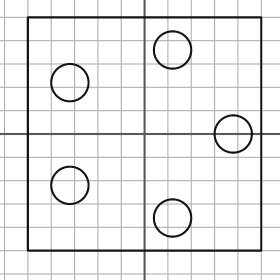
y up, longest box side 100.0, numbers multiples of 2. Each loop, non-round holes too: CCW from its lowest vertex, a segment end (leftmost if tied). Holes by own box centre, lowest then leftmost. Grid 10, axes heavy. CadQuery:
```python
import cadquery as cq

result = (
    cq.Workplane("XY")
    .moveTo(-50.0, -50.0)
    .lineTo(50.0, -50.0)
    .lineTo(50.0, 50.0)
    .lineTo(-50.0, 50.0)
    .close()
    .moveTo(12.0, -36.0)
    .circle(8.0)
    .moveTo(-32.0, -22.0)
    .circle(8.0)
    .moveTo(38.0, 0.0)
    .circle(8.0)
    .moveTo(-32.0, 22.0)
    .circle(8.0)
    .moveTo(12.0, 36.0)
    .circle(8.0)
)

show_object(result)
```